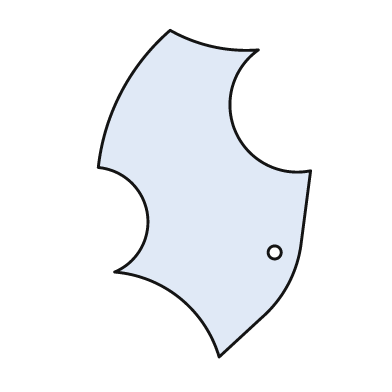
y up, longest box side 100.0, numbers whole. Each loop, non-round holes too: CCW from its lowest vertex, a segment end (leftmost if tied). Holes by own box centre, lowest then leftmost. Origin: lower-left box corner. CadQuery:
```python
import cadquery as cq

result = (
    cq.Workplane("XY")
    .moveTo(37.0, 0.0)
    .lineTo(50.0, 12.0)
    .threePointArc((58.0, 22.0), (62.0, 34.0))
    .lineTo(65.0, 57.0)
    .threePointArc((42.0, 69.0), (49.0, 94.0))
    .threePointArc((35.0, 95.0), (22.0, 100.0))
    .threePointArc((7.0, 81.0), (0.0, 58.0))
    .threePointArc((15.0, 44.0), (5.0, 26.0))
    .threePointArc((25.0, 18.0), (37.0, 0.0))
    .close()
    .moveTo(54.0, 32.0)
    .circle(2.0)
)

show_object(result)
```